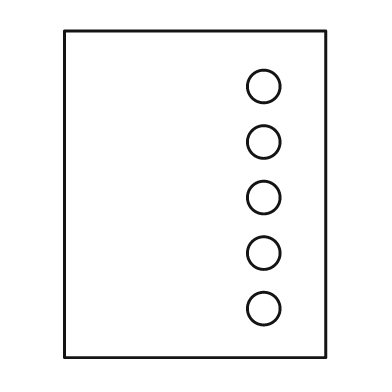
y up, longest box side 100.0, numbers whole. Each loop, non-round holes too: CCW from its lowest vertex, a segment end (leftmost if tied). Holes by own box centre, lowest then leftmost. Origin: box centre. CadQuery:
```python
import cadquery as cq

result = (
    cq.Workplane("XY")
    .moveTo(-40.0, -50.0)
    .lineTo(40.0, -50.0)
    .lineTo(40.0, 50.0)
    .lineTo(-40.0, 50.0)
    .close()
    .moveTo(21.0, -35.0)
    .circle(5.0)
    .moveTo(21.0, -18.0)
    .circle(5.0)
    .moveTo(21.0, -1.0)
    .circle(5.0)
    .moveTo(21.0, 16.0)
    .circle(5.0)
    .moveTo(21.0, 33.0)
    .circle(5.0)
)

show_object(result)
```